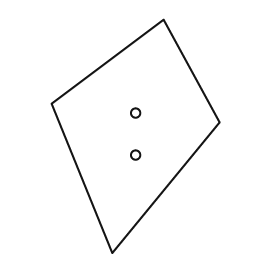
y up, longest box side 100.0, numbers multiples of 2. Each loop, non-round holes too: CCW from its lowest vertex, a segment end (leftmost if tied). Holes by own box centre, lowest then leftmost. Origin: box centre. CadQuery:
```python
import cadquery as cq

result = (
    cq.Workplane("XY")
    .moveTo(-10.0, -50.0)
    .lineTo(36.0, 6.0)
    .lineTo(12.0, 50.0)
    .lineTo(-36.0, 14.0)
    .close()
    .moveTo(0.0, -8.0)
    .circle(2.0)
    .moveTo(0.0, 10.0)
    .circle(2.0)
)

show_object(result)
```